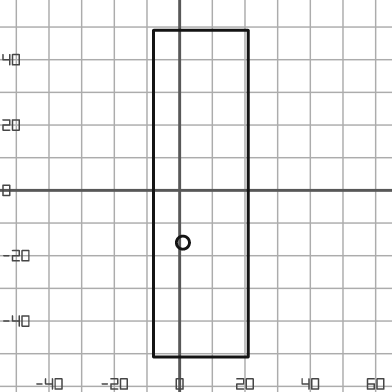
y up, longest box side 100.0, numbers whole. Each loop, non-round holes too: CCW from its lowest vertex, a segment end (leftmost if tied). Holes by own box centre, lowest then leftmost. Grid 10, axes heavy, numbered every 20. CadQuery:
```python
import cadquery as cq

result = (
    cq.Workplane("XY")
    .moveTo(-8.0, -51.0)
    .lineTo(21.0, -51.0)
    .lineTo(21.0, 49.0)
    .lineTo(-8.0, 49.0)
    .close()
    .moveTo(1.0, -16.0)
    .circle(2.0)
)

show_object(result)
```